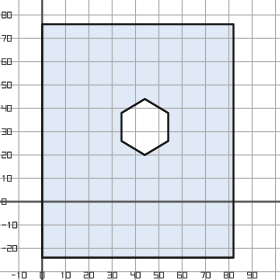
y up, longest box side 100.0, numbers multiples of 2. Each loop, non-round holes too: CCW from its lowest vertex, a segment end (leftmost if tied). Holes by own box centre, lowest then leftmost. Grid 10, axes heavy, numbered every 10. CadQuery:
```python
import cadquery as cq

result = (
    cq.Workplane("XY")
    .moveTo(0.0, -24.0)
    .lineTo(82.0, -24.0)
    .lineTo(82.0, 76.0)
    .lineTo(0.0, 76.0)
    .close()
    .moveTo(44.0, 20.0)
    .lineTo(54.0, 26.0)
    .lineTo(54.0, 38.0)
    .lineTo(44.0, 44.0)
    .lineTo(34.0, 38.0)
    .lineTo(34.0, 26.0)
    .close()
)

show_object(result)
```